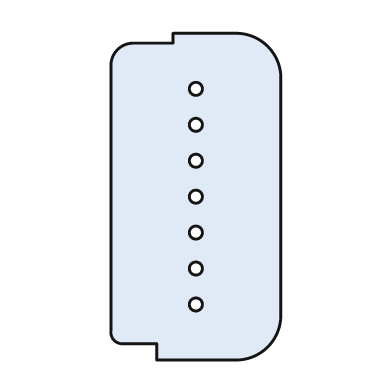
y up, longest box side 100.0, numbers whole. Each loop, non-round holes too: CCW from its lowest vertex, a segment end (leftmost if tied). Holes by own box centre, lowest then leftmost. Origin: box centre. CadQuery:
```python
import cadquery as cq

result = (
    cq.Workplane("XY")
    .moveTo(-12.0, -50.0)
    .lineTo(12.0, -50.0)
    .threePointArc((22.0, -46.0), (26.0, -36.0))
    .lineTo(26.0, 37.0)
    .threePointArc((22.0, 46.0), (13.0, 50.0))
    .lineTo(-7.0, 50.0)
    .lineTo(-7.0, 47.0)
    .lineTo(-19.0, 47.0)
    .threePointArc((-24.0, 45.0), (-26.0, 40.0))
    .lineTo(-26.0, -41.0)
    .threePointArc((-25.0, -44.0), (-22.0, -45.0))
    .lineTo(-12.0, -45.0)
    .close()
    .moveTo(0.0, -33.0)
    .circle(2.0)
    .moveTo(0.0, -22.0)
    .circle(2.0)
    .moveTo(0.0, -11.0)
    .circle(2.0)
    .moveTo(0.0, 0.0)
    .circle(2.0)
    .moveTo(0.0, 11.0)
    .circle(2.0)
    .moveTo(0.0, 22.0)
    .circle(2.0)
    .moveTo(0.0, 33.0)
    .circle(2.0)
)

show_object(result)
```